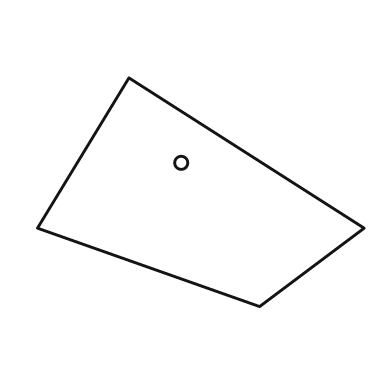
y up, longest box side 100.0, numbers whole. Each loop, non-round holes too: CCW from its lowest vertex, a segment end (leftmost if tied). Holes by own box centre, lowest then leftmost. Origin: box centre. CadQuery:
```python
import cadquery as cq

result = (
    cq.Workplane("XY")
    .moveTo(18.0, -35.0)
    .lineTo(50.0, -11.0)
    .lineTo(-22.0, 35.0)
    .lineTo(-50.0, -11.0)
    .close()
    .moveTo(-6.0, 9.0)
    .circle(2.0)
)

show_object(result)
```